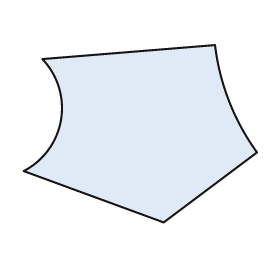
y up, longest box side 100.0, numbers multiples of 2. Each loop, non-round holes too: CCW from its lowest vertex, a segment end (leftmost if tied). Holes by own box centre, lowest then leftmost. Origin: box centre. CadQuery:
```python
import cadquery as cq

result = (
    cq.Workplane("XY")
    .moveTo(10.0, -38.0)
    .lineTo(50.0, -8.0)
    .threePointArc((38.0, 14.0), (32.0, 38.0))
    .lineTo(-42.0, 32.0)
    .threePointArc((-34.0, 6.0), (-50.0, -16.0))
    .close()
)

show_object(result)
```